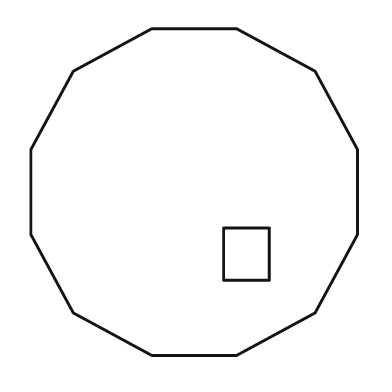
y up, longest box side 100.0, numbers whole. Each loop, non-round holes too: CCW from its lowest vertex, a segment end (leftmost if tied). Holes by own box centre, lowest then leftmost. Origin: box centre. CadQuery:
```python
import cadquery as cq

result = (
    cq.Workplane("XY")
    .moveTo(-13.0, -50.0)
    .lineTo(13.0, -50.0)
    .lineTo(37.0, -37.0)
    .lineTo(50.0, -13.0)
    .lineTo(50.0, 13.0)
    .lineTo(37.0, 37.0)
    .lineTo(13.0, 50.0)
    .lineTo(-13.0, 50.0)
    .lineTo(-37.0, 37.0)
    .lineTo(-50.0, 13.0)
    .lineTo(-50.0, -13.0)
    .lineTo(-37.0, -37.0)
    .close()
    .moveTo(9.0, -27.0)
    .lineTo(23.0, -27.0)
    .lineTo(23.0, -11.0)
    .lineTo(9.0, -11.0)
    .close()
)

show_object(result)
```